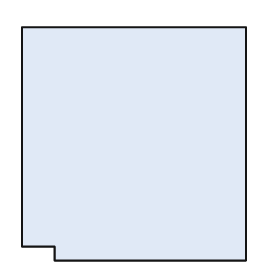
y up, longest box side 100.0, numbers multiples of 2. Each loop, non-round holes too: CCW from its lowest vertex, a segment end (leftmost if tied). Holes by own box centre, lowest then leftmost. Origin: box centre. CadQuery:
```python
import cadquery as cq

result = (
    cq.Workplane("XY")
    .moveTo(-34.0, -50.0)
    .lineTo(48.0, -50.0)
    .lineTo(48.0, 50.0)
    .lineTo(-48.0, 50.0)
    .lineTo(-48.0, -44.0)
    .lineTo(-34.0, -44.0)
    .close()
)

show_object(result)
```